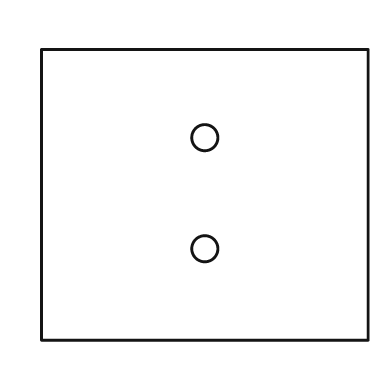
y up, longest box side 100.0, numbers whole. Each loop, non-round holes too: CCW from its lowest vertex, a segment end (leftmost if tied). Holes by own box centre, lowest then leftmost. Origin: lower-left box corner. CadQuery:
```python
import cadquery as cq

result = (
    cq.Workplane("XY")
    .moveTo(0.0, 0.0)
    .lineTo(100.0, 0.0)
    .lineTo(100.0, 89.0)
    .lineTo(0.0, 89.0)
    .close()
    .moveTo(50.0, 28.0)
    .circle(4.0)
    .moveTo(50.0, 62.0)
    .circle(4.0)
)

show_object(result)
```